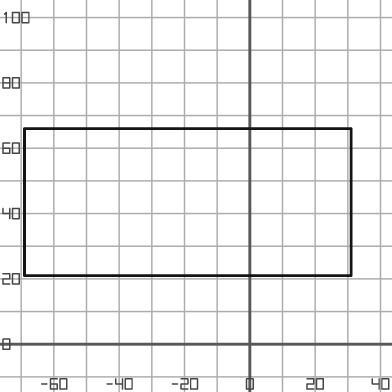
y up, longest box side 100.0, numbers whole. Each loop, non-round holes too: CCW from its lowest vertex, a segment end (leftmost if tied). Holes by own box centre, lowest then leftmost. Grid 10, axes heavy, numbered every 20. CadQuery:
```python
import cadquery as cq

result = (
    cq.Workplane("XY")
    .moveTo(-69.0, 21.0)
    .lineTo(31.0, 21.0)
    .lineTo(31.0, 66.0)
    .lineTo(-69.0, 66.0)
    .close()
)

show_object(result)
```